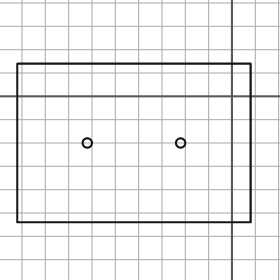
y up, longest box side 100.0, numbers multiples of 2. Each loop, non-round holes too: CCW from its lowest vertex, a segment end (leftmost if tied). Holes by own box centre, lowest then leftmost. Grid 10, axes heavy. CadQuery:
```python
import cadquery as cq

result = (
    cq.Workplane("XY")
    .moveTo(-92.0, -54.0)
    .lineTo(8.0, -54.0)
    .lineTo(8.0, 14.0)
    .lineTo(-92.0, 14.0)
    .close()
    .moveTo(-62.0, -20.0)
    .circle(2.0)
    .moveTo(-22.0, -20.0)
    .circle(2.0)
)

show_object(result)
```